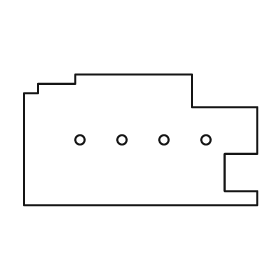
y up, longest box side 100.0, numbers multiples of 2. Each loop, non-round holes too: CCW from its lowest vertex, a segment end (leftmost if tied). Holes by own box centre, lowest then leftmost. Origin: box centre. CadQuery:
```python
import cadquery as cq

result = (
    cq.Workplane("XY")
    .moveTo(-50.0, -28.0)
    .lineTo(50.0, -28.0)
    .lineTo(50.0, -22.0)
    .lineTo(36.0, -22.0)
    .lineTo(36.0, -6.0)
    .lineTo(50.0, -6.0)
    .lineTo(50.0, 14.0)
    .lineTo(22.0, 14.0)
    .lineTo(22.0, 28.0)
    .lineTo(-28.0, 28.0)
    .lineTo(-28.0, 24.0)
    .lineTo(-44.0, 24.0)
    .lineTo(-44.0, 20.0)
    .lineTo(-50.0, 20.0)
    .close()
    .moveTo(-26.0, 0.0)
    .circle(2.0)
    .moveTo(-8.0, 0.0)
    .circle(2.0)
    .moveTo(10.0, 0.0)
    .circle(2.0)
    .moveTo(28.0, 0.0)
    .circle(2.0)
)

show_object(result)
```